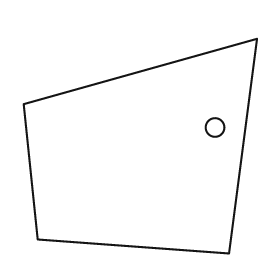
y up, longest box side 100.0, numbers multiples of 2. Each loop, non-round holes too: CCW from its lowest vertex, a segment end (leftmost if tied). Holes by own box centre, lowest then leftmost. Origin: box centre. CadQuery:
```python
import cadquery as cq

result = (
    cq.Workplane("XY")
    .moveTo(38.0, -46.0)
    .lineTo(50.0, 46.0)
    .lineTo(-50.0, 18.0)
    .lineTo(-44.0, -40.0)
    .close()
    .moveTo(32.0, 8.0)
    .circle(4.0)
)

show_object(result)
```